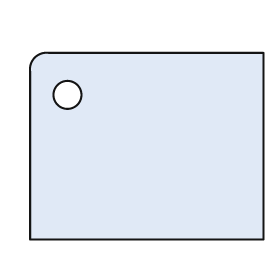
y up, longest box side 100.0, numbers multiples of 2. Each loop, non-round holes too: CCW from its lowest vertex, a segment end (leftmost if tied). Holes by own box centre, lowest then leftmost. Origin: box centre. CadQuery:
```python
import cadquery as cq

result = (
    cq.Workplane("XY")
    .moveTo(-50.0, -40.0)
    .lineTo(50.0, -40.0)
    .lineTo(50.0, 40.0)
    .lineTo(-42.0, 40.0)
    .threePointArc((-48.0, 38.0), (-50.0, 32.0))
    .close()
    .moveTo(-34.0, 22.0)
    .circle(6.0)
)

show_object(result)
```